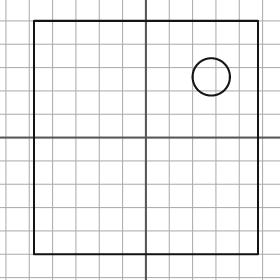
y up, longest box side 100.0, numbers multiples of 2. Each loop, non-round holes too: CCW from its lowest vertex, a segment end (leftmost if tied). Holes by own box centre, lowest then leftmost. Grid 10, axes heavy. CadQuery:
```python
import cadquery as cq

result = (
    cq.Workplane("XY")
    .moveTo(-48.0, -50.0)
    .lineTo(48.0, -50.0)
    .lineTo(48.0, 50.0)
    .lineTo(-48.0, 50.0)
    .close()
    .moveTo(28.0, 26.0)
    .circle(8.0)
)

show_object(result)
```